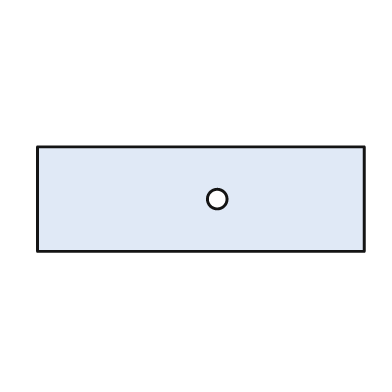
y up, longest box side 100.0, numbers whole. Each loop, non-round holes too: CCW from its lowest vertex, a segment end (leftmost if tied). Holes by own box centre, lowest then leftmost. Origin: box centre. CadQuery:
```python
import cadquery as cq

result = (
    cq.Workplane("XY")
    .moveTo(-50.0, -16.0)
    .lineTo(50.0, -16.0)
    .lineTo(50.0, 16.0)
    .lineTo(-50.0, 16.0)
    .close()
    .moveTo(5.0, 0.0)
    .circle(3.0)
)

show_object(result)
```